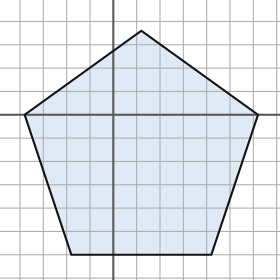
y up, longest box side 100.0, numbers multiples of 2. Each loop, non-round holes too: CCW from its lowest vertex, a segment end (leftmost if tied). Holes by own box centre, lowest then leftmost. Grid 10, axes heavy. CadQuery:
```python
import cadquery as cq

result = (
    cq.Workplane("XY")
    .moveTo(-18.0, -60.0)
    .lineTo(42.0, -60.0)
    .lineTo(62.0, 0.0)
    .lineTo(12.0, 36.0)
    .lineTo(-38.0, 0.0)
    .close()
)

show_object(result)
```